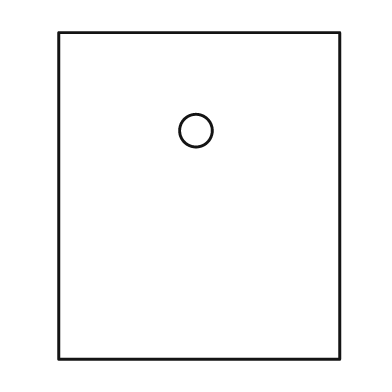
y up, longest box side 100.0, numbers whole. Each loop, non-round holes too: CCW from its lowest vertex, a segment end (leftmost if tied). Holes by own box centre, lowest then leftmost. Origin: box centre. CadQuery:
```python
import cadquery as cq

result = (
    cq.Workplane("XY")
    .moveTo(-43.0, -50.0)
    .lineTo(43.0, -50.0)
    .lineTo(43.0, 50.0)
    .lineTo(-43.0, 50.0)
    .close()
    .moveTo(-1.0, 20.0)
    .circle(5.0)
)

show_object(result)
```